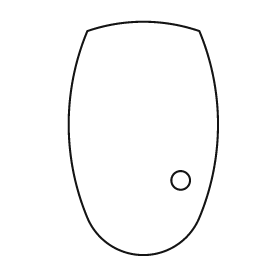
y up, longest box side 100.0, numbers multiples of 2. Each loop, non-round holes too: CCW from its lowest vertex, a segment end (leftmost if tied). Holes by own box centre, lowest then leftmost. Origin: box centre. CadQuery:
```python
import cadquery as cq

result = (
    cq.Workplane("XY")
    .moveTo(-24.0, -34.0)
    .threePointArc((0.0, -50.0), (24.0, -34.0))
    .threePointArc((32.0, 6.0), (24.0, 46.0))
    .threePointArc((0.0, 50.0), (-24.0, 46.0))
    .threePointArc((-32.0, 6.0), (-24.0, -34.0))
    .close()
    .moveTo(16.0, -18.0)
    .circle(4.0)
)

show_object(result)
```